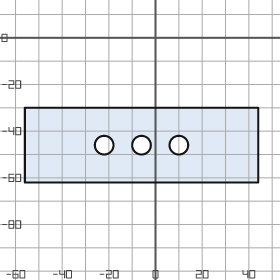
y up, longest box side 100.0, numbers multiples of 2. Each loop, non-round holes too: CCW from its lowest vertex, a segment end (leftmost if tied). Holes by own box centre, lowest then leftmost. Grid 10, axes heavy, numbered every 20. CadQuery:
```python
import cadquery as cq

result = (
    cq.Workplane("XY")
    .moveTo(-56.0, -62.0)
    .lineTo(44.0, -62.0)
    .lineTo(44.0, -30.0)
    .lineTo(-56.0, -30.0)
    .close()
    .moveTo(-22.0, -46.0)
    .circle(4.0)
    .moveTo(-6.0, -46.0)
    .circle(4.0)
    .moveTo(10.0, -46.0)
    .circle(4.0)
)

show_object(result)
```